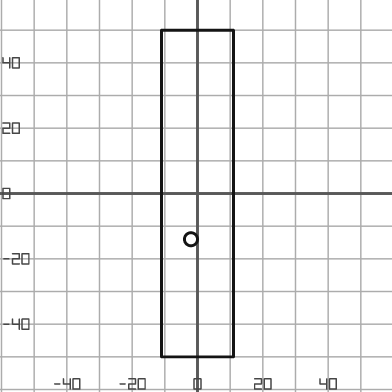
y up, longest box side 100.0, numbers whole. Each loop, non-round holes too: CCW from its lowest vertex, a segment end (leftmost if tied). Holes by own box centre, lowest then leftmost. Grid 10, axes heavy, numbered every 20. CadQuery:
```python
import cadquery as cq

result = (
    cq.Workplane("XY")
    .moveTo(-11.0, -50.0)
    .lineTo(11.0, -50.0)
    .lineTo(11.0, 50.0)
    .lineTo(-11.0, 50.0)
    .close()
    .moveTo(-2.0, -14.0)
    .circle(2.0)
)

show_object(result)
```